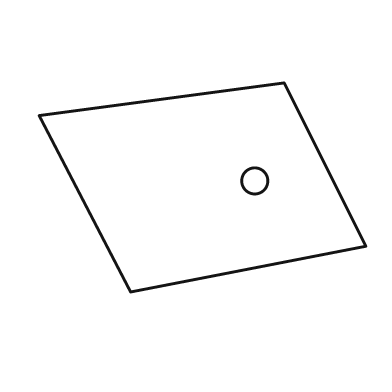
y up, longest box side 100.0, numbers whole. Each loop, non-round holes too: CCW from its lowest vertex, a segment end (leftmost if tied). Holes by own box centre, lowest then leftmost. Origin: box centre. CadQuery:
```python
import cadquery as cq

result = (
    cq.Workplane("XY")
    .moveTo(-22.0, -32.0)
    .lineTo(50.0, -18.0)
    .lineTo(25.0, 32.0)
    .lineTo(-50.0, 22.0)
    .close()
    .moveTo(16.0, 2.0)
    .circle(4.0)
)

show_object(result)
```